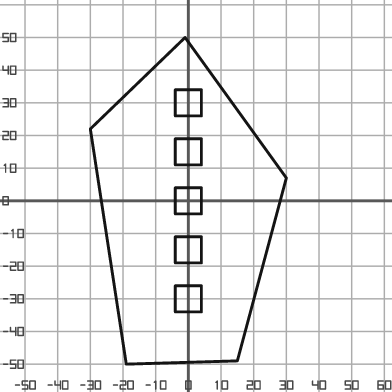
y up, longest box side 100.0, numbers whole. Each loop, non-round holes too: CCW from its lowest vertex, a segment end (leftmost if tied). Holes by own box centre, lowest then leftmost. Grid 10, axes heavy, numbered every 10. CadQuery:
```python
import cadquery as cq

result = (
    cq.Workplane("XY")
    .moveTo(-19.0, -50.0)
    .lineTo(15.0, -49.0)
    .lineTo(30.0, 7.0)
    .lineTo(-1.0, 50.0)
    .lineTo(-30.0, 22.0)
    .close()
    .moveTo(-4.0, -34.0)
    .lineTo(4.0, -34.0)
    .lineTo(4.0, -26.0)
    .lineTo(-4.0, -26.0)
    .close()
    .moveTo(-4.0, -19.0)
    .lineTo(4.0, -19.0)
    .lineTo(4.0, -11.0)
    .lineTo(-4.0, -11.0)
    .close()
    .moveTo(-4.0, -4.0)
    .lineTo(4.0, -4.0)
    .lineTo(4.0, 4.0)
    .lineTo(-4.0, 4.0)
    .close()
    .moveTo(-4.0, 11.0)
    .lineTo(4.0, 11.0)
    .lineTo(4.0, 19.0)
    .lineTo(-4.0, 19.0)
    .close()
    .moveTo(-4.0, 26.0)
    .lineTo(4.0, 26.0)
    .lineTo(4.0, 34.0)
    .lineTo(-4.0, 34.0)
    .close()
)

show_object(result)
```